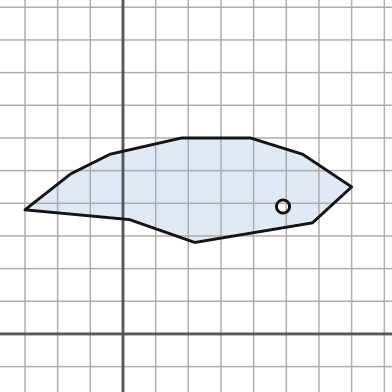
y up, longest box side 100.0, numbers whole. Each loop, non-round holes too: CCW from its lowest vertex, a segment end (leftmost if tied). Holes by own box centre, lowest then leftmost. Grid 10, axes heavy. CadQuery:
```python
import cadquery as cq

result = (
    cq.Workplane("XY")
    .moveTo(22.0, 28.0)
    .lineTo(58.0, 34.0)
    .lineTo(70.0, 45.0)
    .lineTo(55.0, 55.0)
    .lineTo(39.0, 60.0)
    .lineTo(18.0, 60.0)
    .lineTo(-4.0, 55.0)
    .lineTo(-16.0, 49.0)
    .lineTo(-30.0, 38.0)
    .lineTo(2.0, 35.0)
    .close()
    .moveTo(49.0, 39.0)
    .circle(2.0)
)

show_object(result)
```